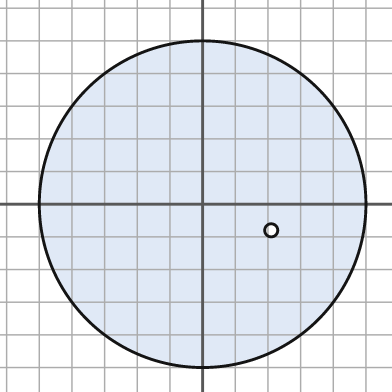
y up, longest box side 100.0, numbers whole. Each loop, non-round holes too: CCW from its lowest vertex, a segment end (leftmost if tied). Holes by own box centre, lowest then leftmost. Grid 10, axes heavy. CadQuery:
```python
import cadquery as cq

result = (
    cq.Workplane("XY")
    .moveTo(0.0, 0.0)
    .circle(50.0)
    .moveTo(21.0, -8.0)
    .circle(2.0)
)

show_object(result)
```